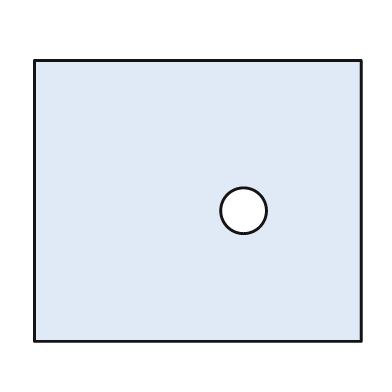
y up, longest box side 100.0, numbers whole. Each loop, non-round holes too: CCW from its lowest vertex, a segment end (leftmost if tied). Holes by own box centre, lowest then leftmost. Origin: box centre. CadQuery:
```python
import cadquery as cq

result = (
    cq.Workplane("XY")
    .moveTo(-50.0, -43.0)
    .lineTo(50.0, -43.0)
    .lineTo(50.0, 43.0)
    .lineTo(-50.0, 43.0)
    .close()
    .moveTo(14.0, -3.0)
    .circle(7.0)
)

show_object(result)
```